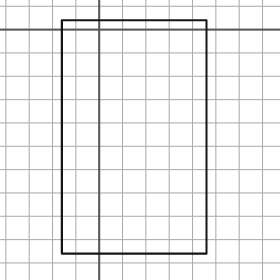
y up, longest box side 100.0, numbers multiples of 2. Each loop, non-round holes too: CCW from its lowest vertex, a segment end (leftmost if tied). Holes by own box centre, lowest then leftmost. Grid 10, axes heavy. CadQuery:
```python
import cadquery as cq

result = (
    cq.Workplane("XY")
    .moveTo(-16.0, -96.0)
    .lineTo(46.0, -96.0)
    .lineTo(46.0, 4.0)
    .lineTo(-16.0, 4.0)
    .close()
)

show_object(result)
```